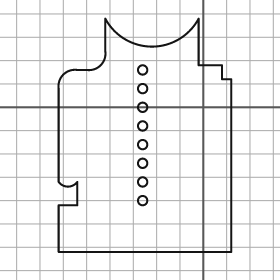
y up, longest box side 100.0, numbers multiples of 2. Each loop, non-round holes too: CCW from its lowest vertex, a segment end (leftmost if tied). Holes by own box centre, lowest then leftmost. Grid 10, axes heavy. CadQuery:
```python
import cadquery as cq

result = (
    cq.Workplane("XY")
    .moveTo(-62.0, -62.0)
    .lineTo(12.0, -62.0)
    .lineTo(12.0, 12.0)
    .lineTo(8.0, 12.0)
    .lineTo(8.0, 18.0)
    .lineTo(-2.0, 18.0)
    .lineTo(-2.0, 38.0)
    .threePointArc((-22.0, 26.0), (-42.0, 38.0))
    .lineTo(-42.0, 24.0)
    .threePointArc((-44.0, 18.0), (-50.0, 16.0))
    .lineTo(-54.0, 16.0)
    .threePointArc((-60.0, 14.0), (-62.0, 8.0))
    .lineTo(-62.0, -32.0)
    .threePointArc((-58.0, -34.0), (-54.0, -32.0))
    .lineTo(-54.0, -42.0)
    .lineTo(-62.0, -42.0)
    .close()
    .moveTo(-26.0, -40.0)
    .circle(2.0)
    .moveTo(-26.0, -32.0)
    .circle(2.0)
    .moveTo(-26.0, -24.0)
    .circle(2.0)
    .moveTo(-26.0, -16.0)
    .circle(2.0)
    .moveTo(-26.0, -8.0)
    .circle(2.0)
    .moveTo(-26.0, 0.0)
    .circle(2.0)
    .moveTo(-26.0, 8.0)
    .circle(2.0)
    .moveTo(-26.0, 16.0)
    .circle(2.0)
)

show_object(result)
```